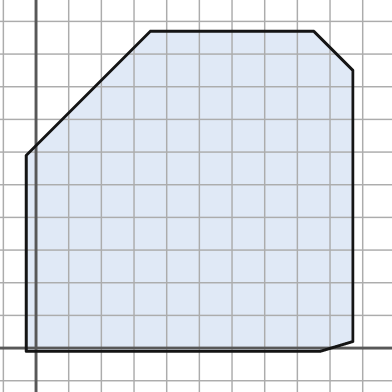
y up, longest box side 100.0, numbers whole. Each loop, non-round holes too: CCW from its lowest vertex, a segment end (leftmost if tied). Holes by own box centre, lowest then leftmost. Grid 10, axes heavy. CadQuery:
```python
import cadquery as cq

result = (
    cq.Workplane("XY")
    .moveTo(-3.0, -1.0)
    .lineTo(87.0, -1.0)
    .lineTo(97.0, 2.0)
    .lineTo(97.0, 85.0)
    .lineTo(85.0, 97.0)
    .lineTo(35.0, 97.0)
    .lineTo(-3.0, 59.0)
    .close()
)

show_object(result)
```